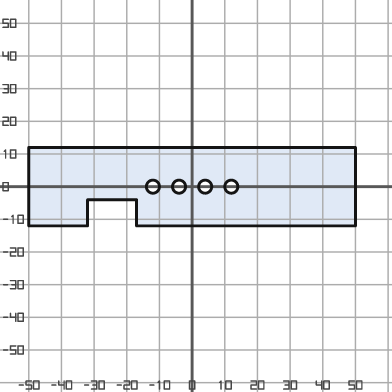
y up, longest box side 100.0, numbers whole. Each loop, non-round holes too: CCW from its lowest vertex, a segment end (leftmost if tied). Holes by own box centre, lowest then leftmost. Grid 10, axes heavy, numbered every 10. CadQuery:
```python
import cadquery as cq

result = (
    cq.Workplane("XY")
    .moveTo(-50.0, -12.0)
    .lineTo(-32.0, -12.0)
    .lineTo(-32.0, -4.0)
    .lineTo(-17.0, -4.0)
    .lineTo(-17.0, -12.0)
    .lineTo(50.0, -12.0)
    .lineTo(50.0, 12.0)
    .lineTo(-50.0, 12.0)
    .close()
    .moveTo(-12.0, 0.0)
    .circle(2.0)
    .moveTo(-4.0, 0.0)
    .circle(2.0)
    .moveTo(4.0, 0.0)
    .circle(2.0)
    .moveTo(12.0, 0.0)
    .circle(2.0)
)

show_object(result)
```